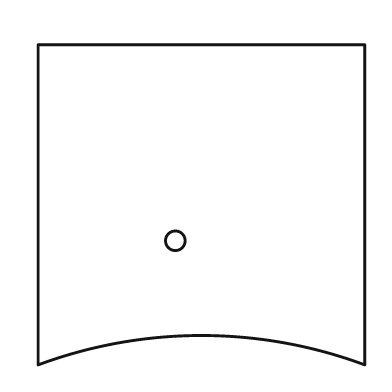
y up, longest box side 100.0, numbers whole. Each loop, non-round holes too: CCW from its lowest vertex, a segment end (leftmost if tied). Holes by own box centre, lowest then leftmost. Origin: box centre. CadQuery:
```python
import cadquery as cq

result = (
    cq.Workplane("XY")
    .moveTo(-50.0, -49.0)
    .threePointArc((0.0, -40.0), (50.0, -49.0))
    .lineTo(50.0, 49.0)
    .lineTo(-50.0, 49.0)
    .close()
    .moveTo(-8.0, -11.0)
    .circle(3.0)
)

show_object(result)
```